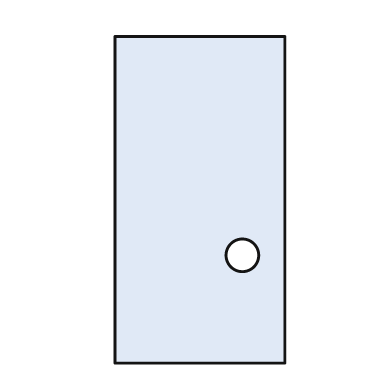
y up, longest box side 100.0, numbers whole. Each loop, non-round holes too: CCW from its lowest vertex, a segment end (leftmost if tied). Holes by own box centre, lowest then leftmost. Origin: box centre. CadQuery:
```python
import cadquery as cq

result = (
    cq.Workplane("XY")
    .moveTo(-26.0, -50.0)
    .lineTo(26.0, -50.0)
    .lineTo(26.0, 50.0)
    .lineTo(-26.0, 50.0)
    .close()
    .moveTo(13.0, -17.0)
    .circle(5.0)
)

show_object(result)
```